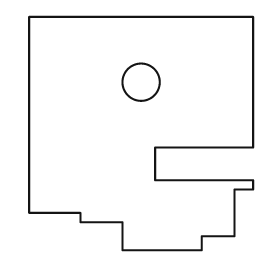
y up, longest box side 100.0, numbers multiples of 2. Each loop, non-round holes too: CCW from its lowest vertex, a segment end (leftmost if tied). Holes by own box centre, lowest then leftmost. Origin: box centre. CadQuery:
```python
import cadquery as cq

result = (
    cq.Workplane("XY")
    .moveTo(-8.0, -50.0)
    .lineTo(26.0, -50.0)
    .lineTo(26.0, -44.0)
    .lineTo(40.0, -44.0)
    .lineTo(40.0, -24.0)
    .lineTo(48.0, -24.0)
    .lineTo(48.0, -20.0)
    .lineTo(6.0, -20.0)
    .lineTo(6.0, -6.0)
    .lineTo(48.0, -6.0)
    .lineTo(48.0, 50.0)
    .lineTo(-48.0, 50.0)
    .lineTo(-48.0, -34.0)
    .lineTo(-26.0, -34.0)
    .lineTo(-26.0, -38.0)
    .lineTo(-8.0, -38.0)
    .close()
    .moveTo(0.0, 22.0)
    .circle(8.0)
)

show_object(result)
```